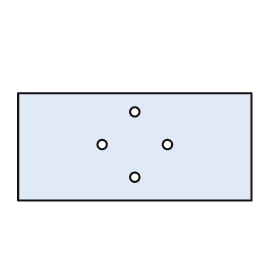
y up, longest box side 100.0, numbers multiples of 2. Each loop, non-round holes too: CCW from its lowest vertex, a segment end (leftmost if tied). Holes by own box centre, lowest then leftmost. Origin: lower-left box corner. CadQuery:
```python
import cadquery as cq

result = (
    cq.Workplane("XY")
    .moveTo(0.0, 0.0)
    .lineTo(100.0, 0.0)
    .lineTo(100.0, 46.0)
    .lineTo(0.0, 46.0)
    .close()
    .moveTo(50.0, 10.0)
    .circle(2.0)
    .moveTo(36.0, 24.0)
    .circle(2.0)
    .moveTo(64.0, 24.0)
    .circle(2.0)
    .moveTo(50.0, 38.0)
    .circle(2.0)
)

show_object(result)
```